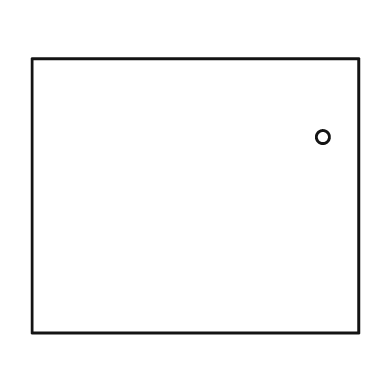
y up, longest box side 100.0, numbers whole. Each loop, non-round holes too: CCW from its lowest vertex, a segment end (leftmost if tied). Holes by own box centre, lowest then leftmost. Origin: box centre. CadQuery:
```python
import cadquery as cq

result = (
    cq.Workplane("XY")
    .moveTo(-50.0, -42.0)
    .lineTo(50.0, -42.0)
    .lineTo(50.0, 42.0)
    .lineTo(-50.0, 42.0)
    .close()
    .moveTo(39.0, 18.0)
    .circle(2.0)
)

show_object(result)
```